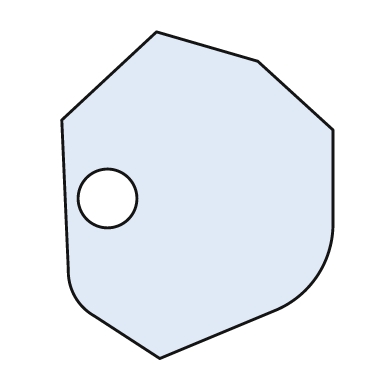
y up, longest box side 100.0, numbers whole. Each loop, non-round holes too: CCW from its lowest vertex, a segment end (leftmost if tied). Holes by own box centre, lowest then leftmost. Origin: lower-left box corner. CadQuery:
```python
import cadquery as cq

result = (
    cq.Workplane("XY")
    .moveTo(30.0, 0.0)
    .lineTo(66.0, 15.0)
    .threePointArc((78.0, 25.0), (83.0, 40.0))
    .lineTo(83.0, 70.0)
    .lineTo(60.0, 91.0)
    .lineTo(29.0, 100.0)
    .lineTo(0.0, 73.0)
    .lineTo(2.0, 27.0)
    .threePointArc((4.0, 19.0), (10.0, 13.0))
    .close()
    .moveTo(14.0, 49.0)
    .circle(9.0)
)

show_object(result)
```